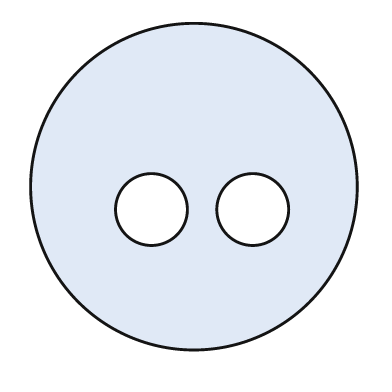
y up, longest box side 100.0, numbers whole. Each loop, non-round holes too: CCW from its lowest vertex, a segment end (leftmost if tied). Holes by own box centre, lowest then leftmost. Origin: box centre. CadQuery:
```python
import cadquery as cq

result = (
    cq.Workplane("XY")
    .moveTo(0.0, 0.0)
    .circle(50.0)
    .moveTo(-13.0, -7.0)
    .circle(11.0)
    .moveTo(18.0, -7.0)
    .circle(11.0)
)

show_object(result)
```